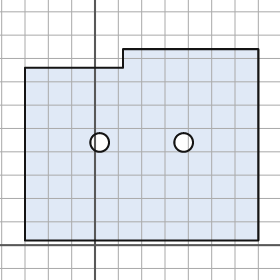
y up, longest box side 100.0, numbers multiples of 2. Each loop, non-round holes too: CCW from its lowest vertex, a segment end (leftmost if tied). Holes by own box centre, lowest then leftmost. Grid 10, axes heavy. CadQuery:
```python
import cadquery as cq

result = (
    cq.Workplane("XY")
    .moveTo(-30.0, 2.0)
    .lineTo(70.0, 2.0)
    .lineTo(70.0, 84.0)
    .lineTo(12.0, 84.0)
    .lineTo(12.0, 76.0)
    .lineTo(-30.0, 76.0)
    .close()
    .moveTo(2.0, 44.0)
    .circle(4.0)
    .moveTo(38.0, 44.0)
    .circle(4.0)
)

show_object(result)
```